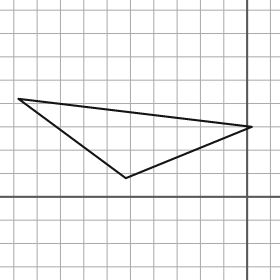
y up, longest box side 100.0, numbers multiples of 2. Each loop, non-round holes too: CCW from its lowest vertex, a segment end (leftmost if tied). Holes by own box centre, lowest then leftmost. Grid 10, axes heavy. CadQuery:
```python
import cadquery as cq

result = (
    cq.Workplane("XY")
    .moveTo(-52.0, 8.0)
    .lineTo(2.0, 30.0)
    .lineTo(-98.0, 42.0)
    .close()
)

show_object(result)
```